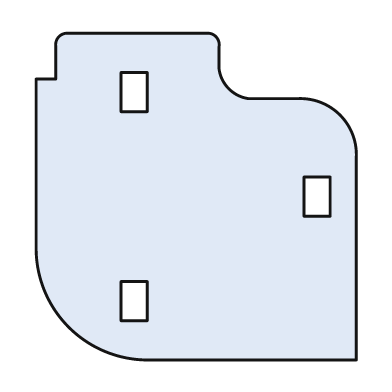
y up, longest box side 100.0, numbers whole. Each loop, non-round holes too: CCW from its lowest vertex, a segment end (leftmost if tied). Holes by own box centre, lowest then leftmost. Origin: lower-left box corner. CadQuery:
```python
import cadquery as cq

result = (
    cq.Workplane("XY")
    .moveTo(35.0, 0.0)
    .lineTo(98.0, 0.0)
    .lineTo(98.0, 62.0)
    .threePointArc((93.0, 75.0), (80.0, 80.0))
    .lineTo(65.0, 80.0)
    .threePointArc((59.0, 83.0), (56.0, 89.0))
    .lineTo(56.0, 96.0)
    .threePointArc((55.0, 99.0), (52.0, 100.0))
    .lineTo(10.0, 100.0)
    .threePointArc((7.0, 99.0), (6.0, 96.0))
    .lineTo(6.0, 86.0)
    .lineTo(0.0, 86.0)
    .lineTo(0.0, 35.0)
    .threePointArc((10.0, 10.0), (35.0, 0.0))
    .close()
    .moveTo(26.0, 12.0)
    .lineTo(34.0, 12.0)
    .lineTo(34.0, 24.0)
    .lineTo(26.0, 24.0)
    .close()
    .moveTo(82.0, 44.0)
    .lineTo(90.0, 44.0)
    .lineTo(90.0, 56.0)
    .lineTo(82.0, 56.0)
    .close()
    .moveTo(26.0, 76.0)
    .lineTo(34.0, 76.0)
    .lineTo(34.0, 88.0)
    .lineTo(26.0, 88.0)
    .close()
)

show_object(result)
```